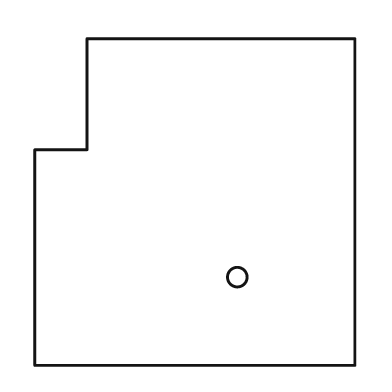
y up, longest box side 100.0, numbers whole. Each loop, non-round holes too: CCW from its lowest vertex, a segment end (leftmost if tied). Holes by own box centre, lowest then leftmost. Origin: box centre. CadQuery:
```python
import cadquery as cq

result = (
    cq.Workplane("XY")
    .moveTo(-49.0, -50.0)
    .lineTo(49.0, -50.0)
    .lineTo(49.0, 50.0)
    .lineTo(-33.0, 50.0)
    .lineTo(-33.0, 16.0)
    .lineTo(-49.0, 16.0)
    .close()
    .moveTo(13.0, -23.0)
    .circle(3.0)
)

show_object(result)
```